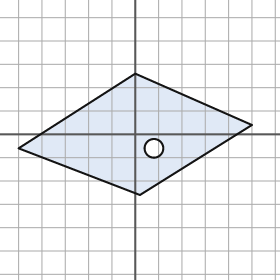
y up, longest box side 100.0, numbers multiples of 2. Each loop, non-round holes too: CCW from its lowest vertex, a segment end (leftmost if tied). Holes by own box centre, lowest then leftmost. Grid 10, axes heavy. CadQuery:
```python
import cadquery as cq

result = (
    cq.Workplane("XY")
    .moveTo(2.0, -26.0)
    .lineTo(50.0, 4.0)
    .lineTo(0.0, 26.0)
    .lineTo(-50.0, -6.0)
    .close()
    .moveTo(8.0, -6.0)
    .circle(4.0)
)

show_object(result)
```